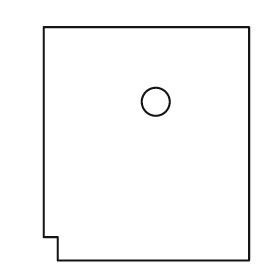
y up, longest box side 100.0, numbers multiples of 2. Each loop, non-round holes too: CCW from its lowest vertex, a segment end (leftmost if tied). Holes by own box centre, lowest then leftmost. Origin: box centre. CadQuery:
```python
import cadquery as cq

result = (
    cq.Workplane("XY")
    .moveTo(-38.0, -50.0)
    .lineTo(44.0, -50.0)
    .lineTo(44.0, 50.0)
    .lineTo(-44.0, 50.0)
    .lineTo(-44.0, -40.0)
    .lineTo(-38.0, -40.0)
    .close()
    .moveTo(4.0, 18.0)
    .circle(6.0)
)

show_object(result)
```